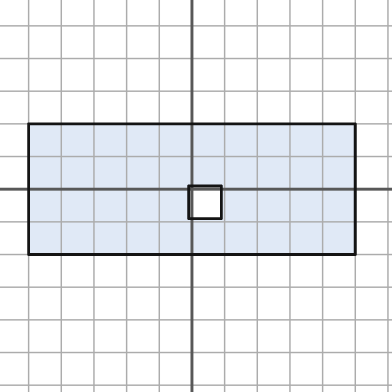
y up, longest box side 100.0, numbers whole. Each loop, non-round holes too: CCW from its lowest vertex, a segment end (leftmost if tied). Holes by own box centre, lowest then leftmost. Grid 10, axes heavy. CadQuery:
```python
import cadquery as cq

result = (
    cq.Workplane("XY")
    .moveTo(-50.0, -20.0)
    .lineTo(50.0, -20.0)
    .lineTo(50.0, 20.0)
    .lineTo(-50.0, 20.0)
    .close()
    .moveTo(-1.0, -9.0)
    .lineTo(9.0, -9.0)
    .lineTo(9.0, 1.0)
    .lineTo(-1.0, 1.0)
    .close()
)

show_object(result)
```